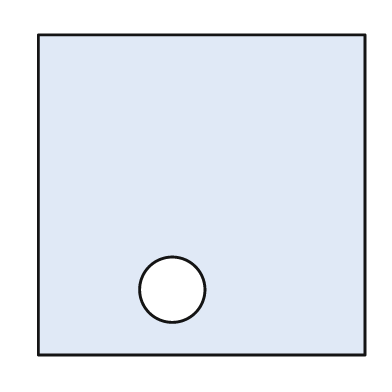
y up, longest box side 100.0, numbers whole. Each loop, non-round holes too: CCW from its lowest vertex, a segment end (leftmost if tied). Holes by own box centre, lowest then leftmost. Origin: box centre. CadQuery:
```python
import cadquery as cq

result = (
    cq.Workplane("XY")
    .moveTo(-50.0, -49.0)
    .lineTo(50.0, -49.0)
    .lineTo(50.0, 49.0)
    .lineTo(-50.0, 49.0)
    .close()
    .moveTo(-9.0, -29.0)
    .circle(10.0)
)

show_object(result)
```